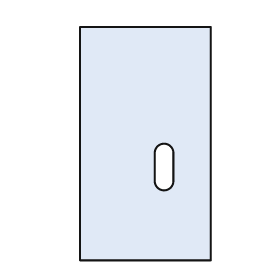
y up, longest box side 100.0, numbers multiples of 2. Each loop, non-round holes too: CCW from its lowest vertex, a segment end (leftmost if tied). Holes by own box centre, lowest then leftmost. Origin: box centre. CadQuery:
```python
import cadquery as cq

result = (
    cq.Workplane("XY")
    .moveTo(-28.0, -50.0)
    .lineTo(28.0, -50.0)
    .lineTo(28.0, 50.0)
    .lineTo(-28.0, 50.0)
    .close()
    .moveTo(4.0, -16.0)
    .threePointArc((8.0, -20.0), (12.0, -16.0))
    .lineTo(12.0, -4.0)
    .threePointArc((8.0, 0.0), (4.0, -4.0))
    .close()
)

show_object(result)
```